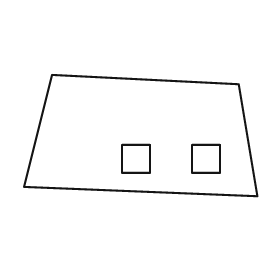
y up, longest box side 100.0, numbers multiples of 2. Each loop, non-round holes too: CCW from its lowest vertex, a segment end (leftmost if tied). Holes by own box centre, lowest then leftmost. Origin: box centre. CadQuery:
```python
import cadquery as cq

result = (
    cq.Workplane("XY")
    .moveTo(50.0, -26.0)
    .lineTo(42.0, 22.0)
    .lineTo(-38.0, 26.0)
    .lineTo(-50.0, -22.0)
    .close()
    .moveTo(-8.0, -16.0)
    .lineTo(4.0, -16.0)
    .lineTo(4.0, -4.0)
    .lineTo(-8.0, -4.0)
    .close()
    .moveTo(22.0, -16.0)
    .lineTo(34.0, -16.0)
    .lineTo(34.0, -4.0)
    .lineTo(22.0, -4.0)
    .close()
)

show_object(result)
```